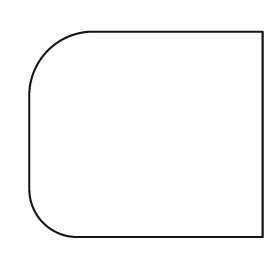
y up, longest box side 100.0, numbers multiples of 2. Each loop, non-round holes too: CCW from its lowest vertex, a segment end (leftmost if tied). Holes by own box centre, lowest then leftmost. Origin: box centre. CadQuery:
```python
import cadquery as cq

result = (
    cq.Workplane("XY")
    .moveTo(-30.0, -44.0)
    .lineTo(50.0, -44.0)
    .lineTo(50.0, 44.0)
    .lineTo(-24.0, 44.0)
    .threePointArc((-42.0, 36.0), (-50.0, 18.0))
    .lineTo(-50.0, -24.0)
    .threePointArc((-44.0, -38.0), (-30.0, -44.0))
    .close()
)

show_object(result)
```